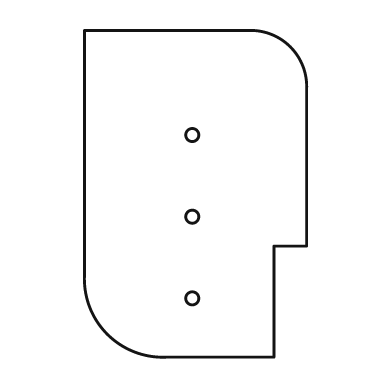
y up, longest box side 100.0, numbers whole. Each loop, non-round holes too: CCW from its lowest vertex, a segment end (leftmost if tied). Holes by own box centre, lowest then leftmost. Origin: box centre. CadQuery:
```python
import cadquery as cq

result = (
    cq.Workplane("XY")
    .moveTo(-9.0, -50.0)
    .lineTo(24.0, -50.0)
    .lineTo(24.0, -16.0)
    .lineTo(34.0, -16.0)
    .lineTo(34.0, 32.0)
    .threePointArc((29.0, 45.0), (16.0, 50.0))
    .lineTo(-34.0, 50.0)
    .lineTo(-34.0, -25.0)
    .threePointArc((-27.0, -43.0), (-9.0, -50.0))
    .close()
    .moveTo(-1.0, -32.0)
    .circle(2.0)
    .moveTo(-1.0, -7.0)
    .circle(2.0)
    .moveTo(-1.0, 18.0)
    .circle(2.0)
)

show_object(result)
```